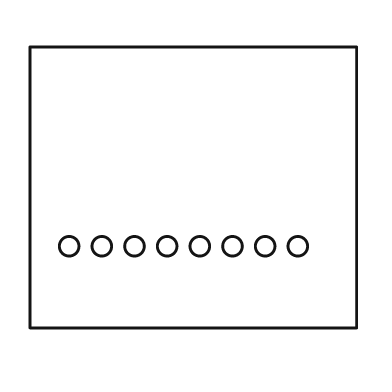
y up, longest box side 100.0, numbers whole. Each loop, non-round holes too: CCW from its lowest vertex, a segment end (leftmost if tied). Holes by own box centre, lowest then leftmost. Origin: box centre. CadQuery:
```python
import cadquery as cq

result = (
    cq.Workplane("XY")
    .moveTo(-50.0, -43.0)
    .lineTo(50.0, -43.0)
    .lineTo(50.0, 43.0)
    .lineTo(-50.0, 43.0)
    .close()
    .moveTo(-38.0, -18.0)
    .circle(3.0)
    .moveTo(-28.0, -18.0)
    .circle(3.0)
    .moveTo(-18.0, -18.0)
    .circle(3.0)
    .moveTo(-8.0, -18.0)
    .circle(3.0)
    .moveTo(2.0, -18.0)
    .circle(3.0)
    .moveTo(12.0, -18.0)
    .circle(3.0)
    .moveTo(22.0, -18.0)
    .circle(3.0)
    .moveTo(32.0, -18.0)
    .circle(3.0)
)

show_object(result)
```